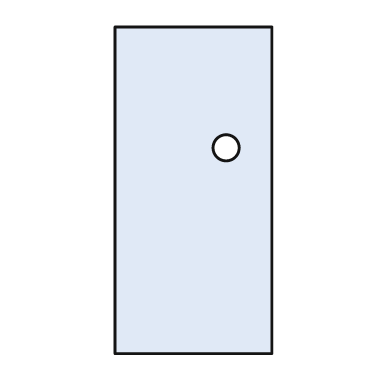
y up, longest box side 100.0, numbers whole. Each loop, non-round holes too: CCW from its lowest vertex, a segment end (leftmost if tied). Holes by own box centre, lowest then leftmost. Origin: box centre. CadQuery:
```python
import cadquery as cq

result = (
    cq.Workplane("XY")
    .moveTo(-24.0, -50.0)
    .lineTo(24.0, -50.0)
    .lineTo(24.0, 50.0)
    .lineTo(-24.0, 50.0)
    .close()
    .moveTo(10.0, 13.0)
    .circle(4.0)
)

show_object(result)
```